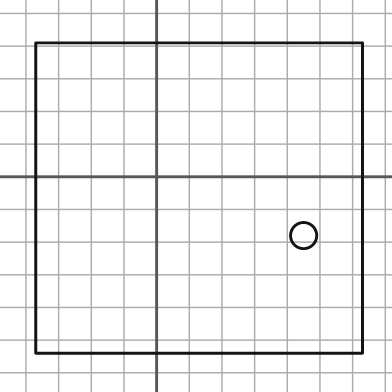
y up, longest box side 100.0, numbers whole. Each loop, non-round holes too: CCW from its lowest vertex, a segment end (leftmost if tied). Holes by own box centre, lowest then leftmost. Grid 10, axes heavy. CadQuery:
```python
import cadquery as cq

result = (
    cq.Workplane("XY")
    .moveTo(-37.0, -54.0)
    .lineTo(63.0, -54.0)
    .lineTo(63.0, 41.0)
    .lineTo(-37.0, 41.0)
    .close()
    .moveTo(45.0, -18.0)
    .circle(4.0)
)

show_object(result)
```